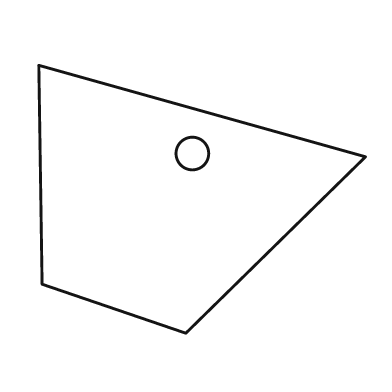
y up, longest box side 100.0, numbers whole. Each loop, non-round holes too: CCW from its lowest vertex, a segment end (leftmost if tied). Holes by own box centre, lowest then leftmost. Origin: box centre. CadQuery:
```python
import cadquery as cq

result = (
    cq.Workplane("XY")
    .moveTo(-5.0, -41.0)
    .lineTo(50.0, 13.0)
    .lineTo(-50.0, 41.0)
    .lineTo(-49.0, -26.0)
    .close()
    .moveTo(-3.0, 14.0)
    .circle(5.0)
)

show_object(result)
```